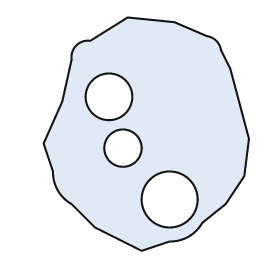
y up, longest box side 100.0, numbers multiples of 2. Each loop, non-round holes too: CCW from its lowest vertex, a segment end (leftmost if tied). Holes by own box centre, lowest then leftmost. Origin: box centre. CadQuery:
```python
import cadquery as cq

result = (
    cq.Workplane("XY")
    .moveTo(-2.0, -50.0)
    .lineTo(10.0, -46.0)
    .threePointArc((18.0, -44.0), (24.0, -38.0))
    .lineTo(34.0, -30.0)
    .lineTo(42.0, -18.0)
    .lineTo(44.0, -2.0)
    .lineTo(36.0, 28.0)
    .lineTo(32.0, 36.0)
    .threePointArc((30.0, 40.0), (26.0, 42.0))
    .lineTo(12.0, 48.0)
    .lineTo(-8.0, 50.0)
    .lineTo(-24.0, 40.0)
    .threePointArc((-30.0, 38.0), (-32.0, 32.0))
    .lineTo(-36.0, 14.0)
    .lineTo(-44.0, -4.0)
    .lineTo(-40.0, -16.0)
    .threePointArc((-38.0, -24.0), (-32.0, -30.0))
    .lineTo(-22.0, -40.0)
    .close()
    .moveTo(10.0, -28.0)
    .circle(12.0)
    .moveTo(-10.0, -6.0)
    .circle(8.0)
    .moveTo(-16.0, 16.0)
    .circle(10.0)
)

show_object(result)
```